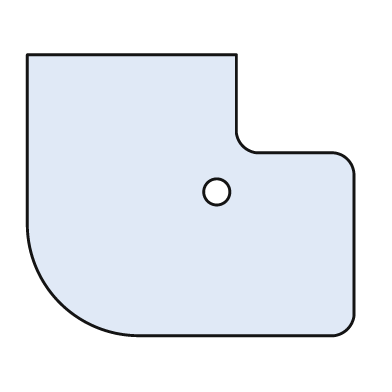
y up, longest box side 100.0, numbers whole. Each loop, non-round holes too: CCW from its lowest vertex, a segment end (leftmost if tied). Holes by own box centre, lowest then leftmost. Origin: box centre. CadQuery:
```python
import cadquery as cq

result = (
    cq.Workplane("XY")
    .moveTo(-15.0, -43.0)
    .lineTo(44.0, -43.0)
    .threePointArc((48.0, -41.0), (50.0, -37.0))
    .lineTo(50.0, 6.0)
    .threePointArc((48.0, 11.0), (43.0, 13.0))
    .lineTo(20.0, 13.0)
    .threePointArc((16.0, 15.0), (14.0, 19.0))
    .lineTo(14.0, 43.0)
    .lineTo(-50.0, 43.0)
    .lineTo(-50.0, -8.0)
    .threePointArc((-40.0, -33.0), (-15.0, -43.0))
    .close()
    .moveTo(8.0, 1.0)
    .circle(4.0)
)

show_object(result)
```